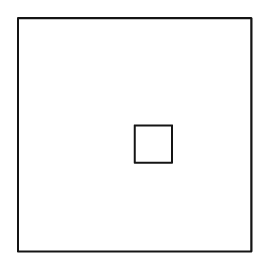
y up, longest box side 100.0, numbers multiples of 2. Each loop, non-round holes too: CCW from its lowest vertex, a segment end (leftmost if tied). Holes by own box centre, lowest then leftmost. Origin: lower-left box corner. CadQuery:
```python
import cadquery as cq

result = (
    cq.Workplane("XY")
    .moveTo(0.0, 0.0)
    .lineTo(100.0, 0.0)
    .lineTo(100.0, 100.0)
    .lineTo(0.0, 100.0)
    .close()
    .moveTo(50.0, 38.0)
    .lineTo(66.0, 38.0)
    .lineTo(66.0, 54.0)
    .lineTo(50.0, 54.0)
    .close()
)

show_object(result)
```